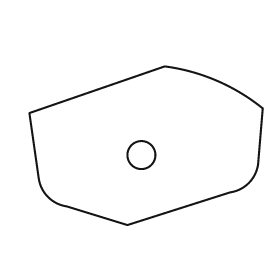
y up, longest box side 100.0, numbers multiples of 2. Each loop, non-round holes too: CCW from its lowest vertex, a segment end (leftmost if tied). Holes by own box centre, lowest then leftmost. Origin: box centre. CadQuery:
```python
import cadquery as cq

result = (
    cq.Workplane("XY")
    .moveTo(-8.0, -34.0)
    .lineTo(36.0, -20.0)
    .threePointArc((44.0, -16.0), (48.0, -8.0))
    .lineTo(50.0, 16.0)
    .threePointArc((30.0, 28.0), (8.0, 34.0))
    .lineTo(-50.0, 14.0)
    .lineTo(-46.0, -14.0)
    .threePointArc((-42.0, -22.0), (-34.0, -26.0))
    .close()
    .moveTo(-2.0, -4.0)
    .circle(6.0)
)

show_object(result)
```